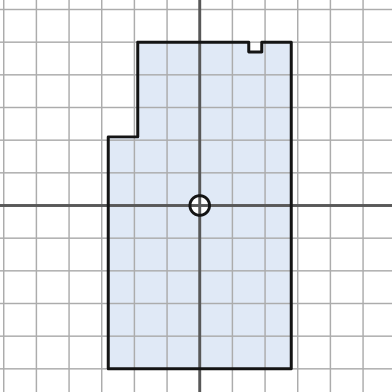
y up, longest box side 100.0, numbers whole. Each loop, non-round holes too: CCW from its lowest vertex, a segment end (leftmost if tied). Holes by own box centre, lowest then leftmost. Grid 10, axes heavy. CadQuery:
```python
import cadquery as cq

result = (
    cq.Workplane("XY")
    .moveTo(-28.0, -50.0)
    .lineTo(28.0, -50.0)
    .lineTo(28.0, 50.0)
    .lineTo(19.0, 50.0)
    .lineTo(19.0, 47.0)
    .lineTo(15.0, 47.0)
    .lineTo(15.0, 50.0)
    .lineTo(-19.0, 50.0)
    .lineTo(-19.0, 21.0)
    .lineTo(-28.0, 21.0)
    .close()
    .moveTo(0.0, 0.0)
    .circle(3.0)
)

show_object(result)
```